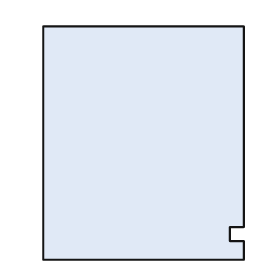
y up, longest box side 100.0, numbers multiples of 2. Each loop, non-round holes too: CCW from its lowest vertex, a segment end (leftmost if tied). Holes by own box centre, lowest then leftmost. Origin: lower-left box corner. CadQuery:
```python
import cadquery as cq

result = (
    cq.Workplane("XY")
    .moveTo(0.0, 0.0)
    .lineTo(86.0, 0.0)
    .lineTo(86.0, 8.0)
    .lineTo(80.0, 8.0)
    .lineTo(80.0, 14.0)
    .lineTo(86.0, 14.0)
    .lineTo(86.0, 100.0)
    .lineTo(0.0, 100.0)
    .close()
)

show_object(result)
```